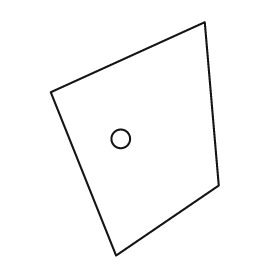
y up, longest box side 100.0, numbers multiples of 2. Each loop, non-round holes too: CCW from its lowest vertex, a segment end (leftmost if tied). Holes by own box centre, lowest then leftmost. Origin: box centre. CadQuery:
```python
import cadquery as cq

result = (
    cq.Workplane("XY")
    .moveTo(-8.0, -50.0)
    .lineTo(36.0, -20.0)
    .lineTo(30.0, 50.0)
    .lineTo(-36.0, 20.0)
    .close()
    .moveTo(-6.0, 0.0)
    .circle(4.0)
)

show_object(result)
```